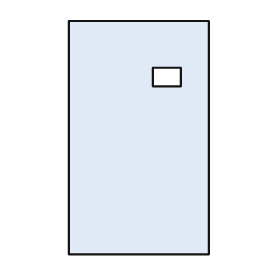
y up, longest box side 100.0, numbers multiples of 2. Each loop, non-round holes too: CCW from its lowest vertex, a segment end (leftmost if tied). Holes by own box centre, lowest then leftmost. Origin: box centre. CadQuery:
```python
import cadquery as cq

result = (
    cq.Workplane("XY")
    .moveTo(-30.0, -50.0)
    .lineTo(30.0, -50.0)
    .lineTo(30.0, 50.0)
    .lineTo(-30.0, 50.0)
    .close()
    .moveTo(6.0, 22.0)
    .lineTo(18.0, 22.0)
    .lineTo(18.0, 30.0)
    .lineTo(6.0, 30.0)
    .close()
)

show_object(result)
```